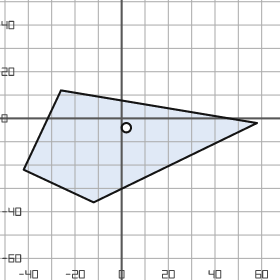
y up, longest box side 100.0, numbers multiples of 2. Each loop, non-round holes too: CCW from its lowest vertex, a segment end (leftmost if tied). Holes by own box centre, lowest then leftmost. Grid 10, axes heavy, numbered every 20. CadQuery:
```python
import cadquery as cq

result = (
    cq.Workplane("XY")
    .moveTo(-12.0, -36.0)
    .lineTo(58.0, -2.0)
    .lineTo(-26.0, 12.0)
    .lineTo(-42.0, -22.0)
    .close()
    .moveTo(2.0, -4.0)
    .circle(2.0)
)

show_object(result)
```